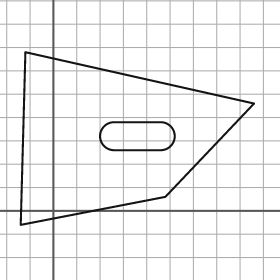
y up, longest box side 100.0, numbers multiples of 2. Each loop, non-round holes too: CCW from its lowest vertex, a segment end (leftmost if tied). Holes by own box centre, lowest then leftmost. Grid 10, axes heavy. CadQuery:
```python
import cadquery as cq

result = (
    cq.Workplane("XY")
    .moveTo(-14.0, -6.0)
    .lineTo(48.0, 6.0)
    .lineTo(86.0, 46.0)
    .lineTo(-12.0, 68.0)
    .close()
    .moveTo(26.0, 26.0)
    .lineTo(46.0, 26.0)
    .threePointArc((52.0, 32.0), (46.0, 38.0))
    .lineTo(26.0, 38.0)
    .threePointArc((20.0, 32.0), (26.0, 26.0))
    .close()
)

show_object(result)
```